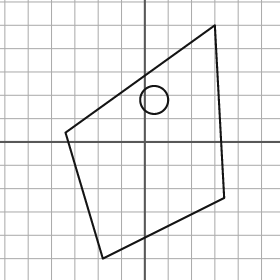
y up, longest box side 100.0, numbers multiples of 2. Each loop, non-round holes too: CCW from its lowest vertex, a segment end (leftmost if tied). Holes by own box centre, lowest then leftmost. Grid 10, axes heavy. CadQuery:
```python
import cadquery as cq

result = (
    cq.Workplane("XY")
    .moveTo(-18.0, -50.0)
    .lineTo(34.0, -24.0)
    .lineTo(30.0, 50.0)
    .lineTo(-34.0, 4.0)
    .close()
    .moveTo(4.0, 18.0)
    .circle(6.0)
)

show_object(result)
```